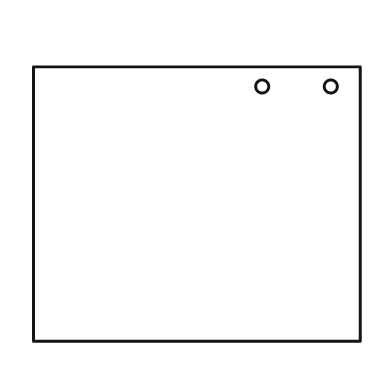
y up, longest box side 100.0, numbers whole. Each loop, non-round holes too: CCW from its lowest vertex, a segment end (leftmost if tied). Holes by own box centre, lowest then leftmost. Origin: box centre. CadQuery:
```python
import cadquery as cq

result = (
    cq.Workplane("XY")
    .moveTo(-50.0, -42.0)
    .lineTo(50.0, -42.0)
    .lineTo(50.0, 42.0)
    .lineTo(-50.0, 42.0)
    .close()
    .moveTo(20.0, 36.0)
    .circle(2.0)
    .moveTo(41.0, 36.0)
    .circle(2.0)
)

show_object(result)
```